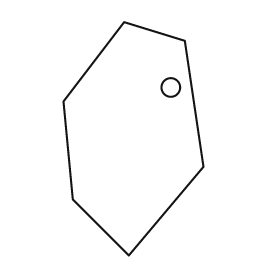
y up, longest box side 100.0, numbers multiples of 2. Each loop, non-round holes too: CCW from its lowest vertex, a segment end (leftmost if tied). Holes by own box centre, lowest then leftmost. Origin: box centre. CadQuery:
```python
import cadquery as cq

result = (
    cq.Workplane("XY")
    .moveTo(-2.0, -50.0)
    .lineTo(30.0, -12.0)
    .lineTo(22.0, 42.0)
    .lineTo(-4.0, 50.0)
    .lineTo(-30.0, 16.0)
    .lineTo(-26.0, -26.0)
    .close()
    .moveTo(16.0, 22.0)
    .circle(4.0)
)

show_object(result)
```